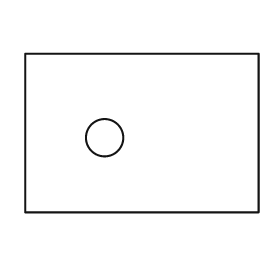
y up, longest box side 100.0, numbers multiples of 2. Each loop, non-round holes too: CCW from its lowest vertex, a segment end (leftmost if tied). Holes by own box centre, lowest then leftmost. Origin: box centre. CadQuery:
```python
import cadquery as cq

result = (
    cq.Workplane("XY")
    .moveTo(-50.0, -34.0)
    .lineTo(50.0, -34.0)
    .lineTo(50.0, 34.0)
    .lineTo(-50.0, 34.0)
    .close()
    .moveTo(-16.0, -2.0)
    .circle(8.0)
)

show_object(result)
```